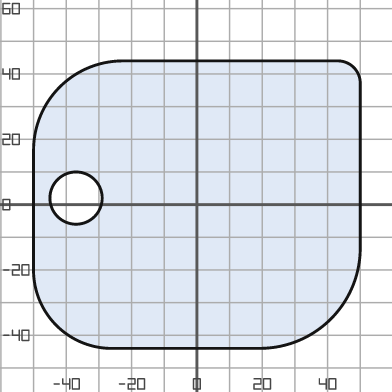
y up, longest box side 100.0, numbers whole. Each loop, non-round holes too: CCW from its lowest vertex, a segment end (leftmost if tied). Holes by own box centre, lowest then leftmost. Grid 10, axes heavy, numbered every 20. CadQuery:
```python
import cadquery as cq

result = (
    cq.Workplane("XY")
    .moveTo(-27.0, -44.0)
    .lineTo(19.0, -44.0)
    .threePointArc((41.0, -35.0), (50.0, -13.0))
    .lineTo(50.0, 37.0)
    .threePointArc((48.0, 42.0), (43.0, 44.0))
    .lineTo(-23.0, 44.0)
    .threePointArc((-42.0, 36.0), (-50.0, 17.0))
    .lineTo(-50.0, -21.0)
    .threePointArc((-43.0, -37.0), (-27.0, -44.0))
    .close()
    .moveTo(-37.0, 2.0)
    .circle(8.0)
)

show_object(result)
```